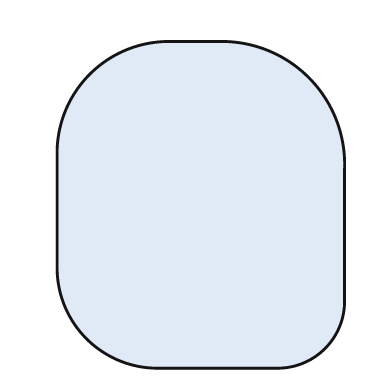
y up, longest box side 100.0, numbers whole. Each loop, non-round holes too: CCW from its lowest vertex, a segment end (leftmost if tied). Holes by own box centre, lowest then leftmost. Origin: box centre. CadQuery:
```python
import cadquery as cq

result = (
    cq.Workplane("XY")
    .moveTo(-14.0, -50.0)
    .lineTo(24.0, -50.0)
    .threePointArc((38.0, -44.0), (44.0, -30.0))
    .lineTo(44.0, 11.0)
    .threePointArc((33.0, 39.0), (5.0, 50.0))
    .lineTo(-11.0, 50.0)
    .threePointArc((-34.0, 40.0), (-44.0, 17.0))
    .lineTo(-44.0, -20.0)
    .threePointArc((-35.0, -41.0), (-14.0, -50.0))
    .close()
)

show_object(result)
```